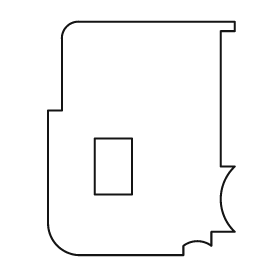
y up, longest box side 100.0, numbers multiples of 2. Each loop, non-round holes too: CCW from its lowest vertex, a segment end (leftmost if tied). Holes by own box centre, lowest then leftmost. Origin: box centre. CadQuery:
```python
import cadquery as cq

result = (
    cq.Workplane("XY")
    .moveTo(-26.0, -50.0)
    .lineTo(18.0, -50.0)
    .lineTo(18.0, -46.0)
    .threePointArc((24.0, -44.0), (30.0, -46.0))
    .lineTo(30.0, -40.0)
    .lineTo(40.0, -40.0)
    .threePointArc((34.0, -26.0), (40.0, -12.0))
    .lineTo(34.0, -12.0)
    .lineTo(34.0, 46.0)
    .lineTo(40.0, 46.0)
    .lineTo(40.0, 50.0)
    .lineTo(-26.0, 50.0)
    .threePointArc((-32.0, 48.0), (-34.0, 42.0))
    .lineTo(-34.0, 12.0)
    .lineTo(-40.0, 12.0)
    .lineTo(-40.0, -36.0)
    .threePointArc((-36.0, -46.0), (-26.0, -50.0))
    .close()
    .moveTo(-20.0, -24.0)
    .lineTo(-4.0, -24.0)
    .lineTo(-4.0, 0.0)
    .lineTo(-20.0, 0.0)
    .close()
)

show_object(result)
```